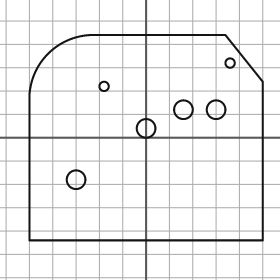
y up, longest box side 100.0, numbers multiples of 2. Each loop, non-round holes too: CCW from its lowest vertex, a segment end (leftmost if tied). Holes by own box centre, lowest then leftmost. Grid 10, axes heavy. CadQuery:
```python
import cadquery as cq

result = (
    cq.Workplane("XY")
    .moveTo(-50.0, -44.0)
    .lineTo(50.0, -44.0)
    .lineTo(50.0, 24.0)
    .lineTo(34.0, 44.0)
    .lineTo(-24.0, 44.0)
    .threePointArc((-42.0, 36.0), (-50.0, 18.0))
    .close()
    .moveTo(-30.0, -18.0)
    .circle(4.0)
    .moveTo(0.0, 4.0)
    .circle(4.0)
    .moveTo(16.0, 12.0)
    .circle(4.0)
    .moveTo(30.0, 12.0)
    .circle(4.0)
    .moveTo(-18.0, 22.0)
    .circle(2.0)
    .moveTo(36.0, 32.0)
    .circle(2.0)
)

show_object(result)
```